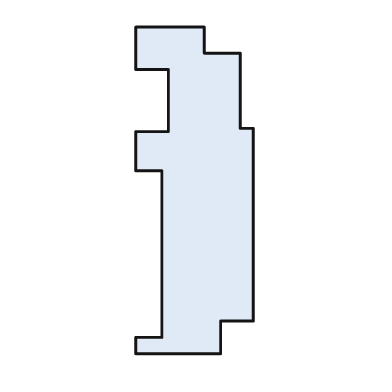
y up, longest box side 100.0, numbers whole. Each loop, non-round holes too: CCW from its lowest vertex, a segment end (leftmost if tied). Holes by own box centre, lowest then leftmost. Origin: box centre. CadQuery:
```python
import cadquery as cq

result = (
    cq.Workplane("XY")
    .moveTo(-18.0, -50.0)
    .lineTo(8.0, -50.0)
    .lineTo(8.0, -40.0)
    .lineTo(18.0, -40.0)
    .lineTo(18.0, 19.0)
    .lineTo(14.0, 19.0)
    .lineTo(14.0, 42.0)
    .lineTo(3.0, 42.0)
    .lineTo(3.0, 50.0)
    .lineTo(-18.0, 50.0)
    .lineTo(-18.0, 37.0)
    .lineTo(-8.0, 37.0)
    .lineTo(-8.0, 18.0)
    .lineTo(-18.0, 18.0)
    .lineTo(-18.0, 6.0)
    .lineTo(-10.0, 6.0)
    .lineTo(-10.0, -45.0)
    .lineTo(-18.0, -45.0)
    .close()
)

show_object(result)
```